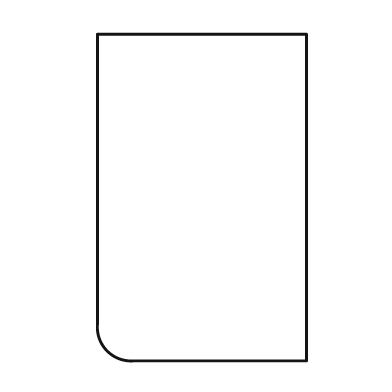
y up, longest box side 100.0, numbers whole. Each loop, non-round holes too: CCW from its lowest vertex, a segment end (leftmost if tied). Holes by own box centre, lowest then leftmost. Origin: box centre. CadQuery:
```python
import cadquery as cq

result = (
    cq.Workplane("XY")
    .moveTo(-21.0, -50.0)
    .lineTo(32.0, -50.0)
    .lineTo(32.0, 50.0)
    .lineTo(-32.0, 50.0)
    .lineTo(-32.0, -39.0)
    .threePointArc((-29.0, -47.0), (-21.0, -50.0))
    .close()
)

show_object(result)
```